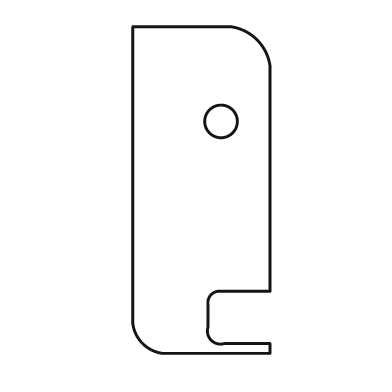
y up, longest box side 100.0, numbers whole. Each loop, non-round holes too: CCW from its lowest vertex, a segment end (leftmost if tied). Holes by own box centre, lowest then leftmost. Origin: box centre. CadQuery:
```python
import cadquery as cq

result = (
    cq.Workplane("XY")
    .moveTo(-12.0, -50.0)
    .lineTo(21.0, -50.0)
    .lineTo(21.0, -47.0)
    .lineTo(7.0, -47.0)
    .threePointArc((3.0, -46.0), (2.0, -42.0))
    .lineTo(2.0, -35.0)
    .threePointArc((3.0, -32.0), (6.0, -31.0))
    .lineTo(21.0, -31.0)
    .lineTo(21.0, 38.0)
    .threePointArc((17.0, 46.0), (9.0, 50.0))
    .lineTo(-21.0, 50.0)
    .lineTo(-21.0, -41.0)
    .threePointArc((-18.0, -47.0), (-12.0, -50.0))
    .close()
    .moveTo(6.0, 21.0)
    .circle(5.0)
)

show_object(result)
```